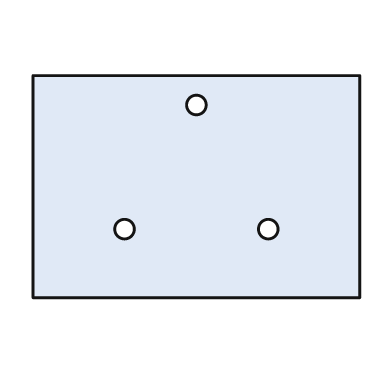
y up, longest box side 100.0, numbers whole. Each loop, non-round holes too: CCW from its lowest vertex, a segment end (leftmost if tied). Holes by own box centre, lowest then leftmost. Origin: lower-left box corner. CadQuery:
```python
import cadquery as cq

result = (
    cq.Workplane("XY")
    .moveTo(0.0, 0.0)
    .lineTo(100.0, 0.0)
    .lineTo(100.0, 68.0)
    .lineTo(0.0, 68.0)
    .close()
    .moveTo(28.0, 21.0)
    .circle(3.0)
    .moveTo(72.0, 21.0)
    .circle(3.0)
    .moveTo(50.0, 59.0)
    .circle(3.0)
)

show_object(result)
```